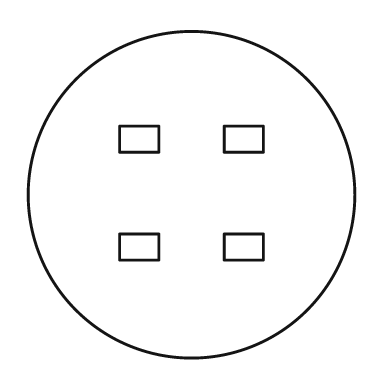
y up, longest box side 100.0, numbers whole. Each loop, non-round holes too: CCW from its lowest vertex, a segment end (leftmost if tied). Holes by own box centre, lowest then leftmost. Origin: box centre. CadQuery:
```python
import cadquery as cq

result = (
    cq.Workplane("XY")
    .moveTo(0.0, 0.0)
    .circle(50.0)
    .moveTo(-22.0, -20.0)
    .lineTo(-10.0, -20.0)
    .lineTo(-10.0, -12.0)
    .lineTo(-22.0, -12.0)
    .close()
    .moveTo(10.0, -20.0)
    .lineTo(22.0, -20.0)
    .lineTo(22.0, -12.0)
    .lineTo(10.0, -12.0)
    .close()
    .moveTo(-22.0, 13.0)
    .lineTo(-10.0, 13.0)
    .lineTo(-10.0, 21.0)
    .lineTo(-22.0, 21.0)
    .close()
    .moveTo(10.0, 13.0)
    .lineTo(22.0, 13.0)
    .lineTo(22.0, 21.0)
    .lineTo(10.0, 21.0)
    .close()
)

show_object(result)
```